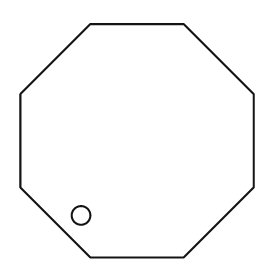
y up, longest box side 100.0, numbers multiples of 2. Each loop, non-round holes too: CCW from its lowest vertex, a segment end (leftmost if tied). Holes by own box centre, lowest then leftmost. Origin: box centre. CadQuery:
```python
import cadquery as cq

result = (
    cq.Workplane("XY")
    .moveTo(-20.0, -50.0)
    .lineTo(20.0, -50.0)
    .lineTo(50.0, -20.0)
    .lineTo(50.0, 20.0)
    .lineTo(20.0, 50.0)
    .lineTo(-20.0, 50.0)
    .lineTo(-50.0, 20.0)
    .lineTo(-50.0, -20.0)
    .close()
    .moveTo(-24.0, -32.0)
    .circle(4.0)
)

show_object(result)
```